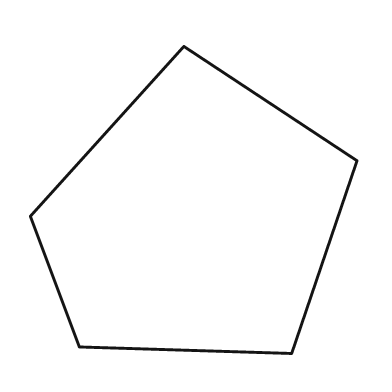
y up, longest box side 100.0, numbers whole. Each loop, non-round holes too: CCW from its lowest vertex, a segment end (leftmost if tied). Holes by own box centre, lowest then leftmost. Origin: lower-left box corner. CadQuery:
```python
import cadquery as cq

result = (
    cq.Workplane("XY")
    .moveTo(80.0, 0.0)
    .lineTo(100.0, 59.0)
    .lineTo(47.0, 94.0)
    .lineTo(0.0, 42.0)
    .lineTo(15.0, 2.0)
    .close()
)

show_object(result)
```